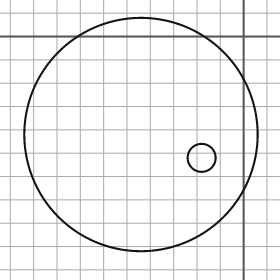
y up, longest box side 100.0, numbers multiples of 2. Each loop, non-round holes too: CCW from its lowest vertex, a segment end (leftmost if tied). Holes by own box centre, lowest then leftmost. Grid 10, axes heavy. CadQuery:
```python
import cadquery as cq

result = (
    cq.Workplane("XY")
    .moveTo(-44.0, -42.0)
    .circle(50.0)
    .moveTo(-18.0, -52.0)
    .circle(6.0)
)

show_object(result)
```